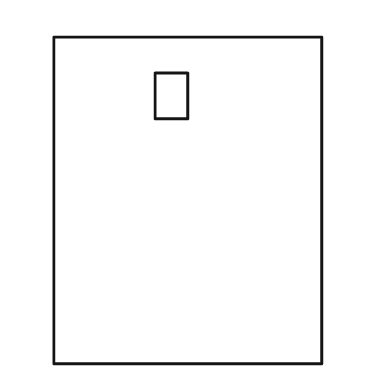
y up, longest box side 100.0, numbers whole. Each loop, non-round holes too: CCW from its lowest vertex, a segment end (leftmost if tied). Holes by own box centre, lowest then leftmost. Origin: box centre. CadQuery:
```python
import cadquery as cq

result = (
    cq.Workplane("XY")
    .moveTo(-41.0, -50.0)
    .lineTo(41.0, -50.0)
    .lineTo(41.0, 50.0)
    .lineTo(-41.0, 50.0)
    .close()
    .moveTo(-10.0, 25.0)
    .lineTo(0.0, 25.0)
    .lineTo(0.0, 39.0)
    .lineTo(-10.0, 39.0)
    .close()
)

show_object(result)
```